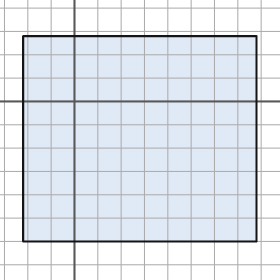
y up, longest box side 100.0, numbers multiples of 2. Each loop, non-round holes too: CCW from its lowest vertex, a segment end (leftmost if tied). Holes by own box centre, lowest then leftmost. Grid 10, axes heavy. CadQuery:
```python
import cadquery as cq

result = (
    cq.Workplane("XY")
    .moveTo(-22.0, -60.0)
    .lineTo(78.0, -60.0)
    .lineTo(78.0, 28.0)
    .lineTo(-22.0, 28.0)
    .close()
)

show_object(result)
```